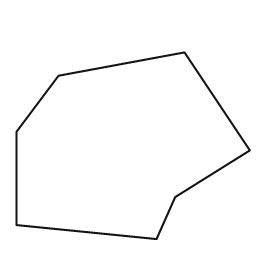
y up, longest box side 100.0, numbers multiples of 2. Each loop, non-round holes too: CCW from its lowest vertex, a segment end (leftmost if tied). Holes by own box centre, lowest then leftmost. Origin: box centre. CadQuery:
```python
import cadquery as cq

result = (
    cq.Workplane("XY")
    .moveTo(10.0, -40.0)
    .lineTo(18.0, -22.0)
    .lineTo(50.0, -2.0)
    .lineTo(22.0, 40.0)
    .lineTo(-32.0, 30.0)
    .lineTo(-50.0, 6.0)
    .lineTo(-50.0, -34.0)
    .close()
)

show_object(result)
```